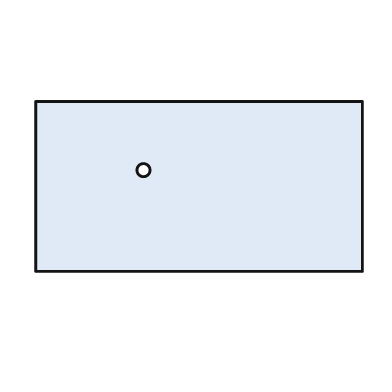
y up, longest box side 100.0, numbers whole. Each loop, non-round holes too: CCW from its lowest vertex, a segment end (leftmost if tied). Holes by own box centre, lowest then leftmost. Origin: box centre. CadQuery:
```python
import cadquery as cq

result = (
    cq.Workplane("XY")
    .moveTo(-50.0, -26.0)
    .lineTo(50.0, -26.0)
    .lineTo(50.0, 26.0)
    .lineTo(-50.0, 26.0)
    .close()
    .moveTo(-17.0, 5.0)
    .circle(2.0)
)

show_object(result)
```